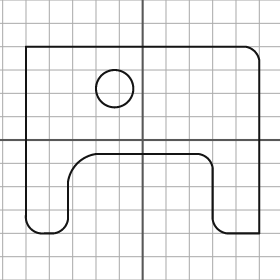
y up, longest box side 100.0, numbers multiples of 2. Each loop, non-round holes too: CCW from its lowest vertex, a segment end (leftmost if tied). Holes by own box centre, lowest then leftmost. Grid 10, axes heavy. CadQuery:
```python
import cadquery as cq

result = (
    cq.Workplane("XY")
    .moveTo(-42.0, -40.0)
    .lineTo(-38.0, -40.0)
    .threePointArc((-34.0, -38.0), (-32.0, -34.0))
    .lineTo(-32.0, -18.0)
    .threePointArc((-28.0, -10.0), (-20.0, -6.0))
    .lineTo(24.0, -6.0)
    .threePointArc((28.0, -8.0), (30.0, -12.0))
    .lineTo(30.0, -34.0)
    .threePointArc((32.0, -38.0), (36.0, -40.0))
    .lineTo(50.0, -40.0)
    .lineTo(50.0, 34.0)
    .threePointArc((48.0, 38.0), (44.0, 40.0))
    .lineTo(-50.0, 40.0)
    .lineTo(-50.0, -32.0)
    .threePointArc((-48.0, -38.0), (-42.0, -40.0))
    .close()
    .moveTo(-12.0, 22.0)
    .circle(8.0)
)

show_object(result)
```